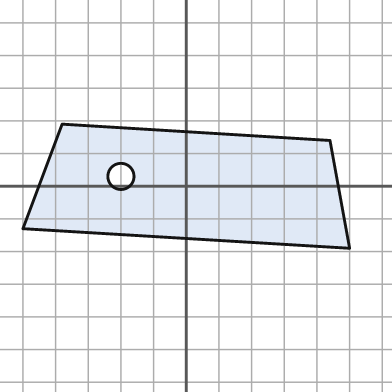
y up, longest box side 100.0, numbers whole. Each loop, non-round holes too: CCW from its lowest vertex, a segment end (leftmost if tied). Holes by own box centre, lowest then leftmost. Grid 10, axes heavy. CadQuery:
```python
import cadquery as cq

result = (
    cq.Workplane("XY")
    .moveTo(50.0, -19.0)
    .lineTo(44.0, 14.0)
    .lineTo(-38.0, 19.0)
    .lineTo(-50.0, -13.0)
    .close()
    .moveTo(-20.0, 3.0)
    .circle(4.0)
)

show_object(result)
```